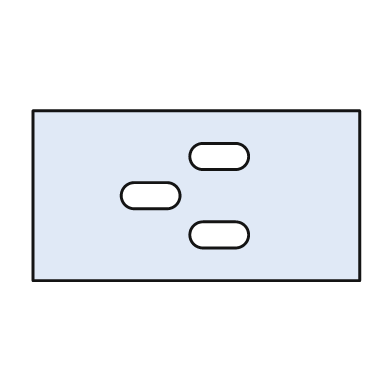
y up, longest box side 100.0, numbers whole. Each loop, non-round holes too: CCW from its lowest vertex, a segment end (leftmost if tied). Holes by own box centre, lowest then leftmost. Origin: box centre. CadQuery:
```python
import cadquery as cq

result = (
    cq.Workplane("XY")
    .moveTo(-50.0, -26.0)
    .lineTo(50.0, -26.0)
    .lineTo(50.0, 26.0)
    .lineTo(-50.0, 26.0)
    .close()
    .moveTo(2.0, -16.0)
    .lineTo(12.0, -16.0)
    .threePointArc((16.0, -12.0), (12.0, -8.0))
    .lineTo(2.0, -8.0)
    .threePointArc((-2.0, -12.0), (2.0, -16.0))
    .close()
    .moveTo(-19.0, -4.0)
    .lineTo(-9.0, -4.0)
    .threePointArc((-5.0, 0.0), (-9.0, 4.0))
    .lineTo(-19.0, 4.0)
    .threePointArc((-23.0, 0.0), (-19.0, -4.0))
    .close()
    .moveTo(2.0, 8.0)
    .lineTo(12.0, 8.0)
    .threePointArc((16.0, 12.0), (12.0, 16.0))
    .lineTo(2.0, 16.0)
    .threePointArc((-2.0, 12.0), (2.0, 8.0))
    .close()
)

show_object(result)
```